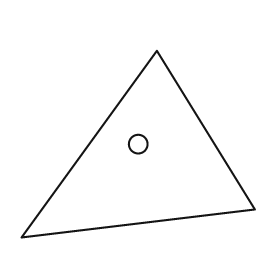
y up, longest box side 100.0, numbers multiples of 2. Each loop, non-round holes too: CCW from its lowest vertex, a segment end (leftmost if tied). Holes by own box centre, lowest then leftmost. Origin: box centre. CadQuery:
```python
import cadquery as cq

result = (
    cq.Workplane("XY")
    .moveTo(-50.0, -40.0)
    .lineTo(50.0, -28.0)
    .lineTo(8.0, 40.0)
    .close()
    .moveTo(0.0, 0.0)
    .circle(4.0)
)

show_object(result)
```